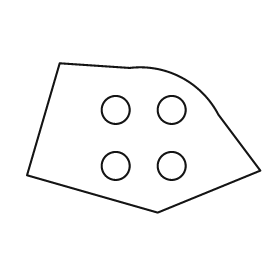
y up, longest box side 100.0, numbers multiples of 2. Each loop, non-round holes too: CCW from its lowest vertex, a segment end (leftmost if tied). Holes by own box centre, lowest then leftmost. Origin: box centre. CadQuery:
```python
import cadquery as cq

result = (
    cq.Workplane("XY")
    .moveTo(6.0, -32.0)
    .lineTo(50.0, -14.0)
    .lineTo(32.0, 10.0)
    .threePointArc((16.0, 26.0), (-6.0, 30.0))
    .lineTo(-36.0, 32.0)
    .lineTo(-50.0, -16.0)
    .close()
    .moveTo(-12.0, -12.0)
    .circle(6.0)
    .moveTo(12.0, -12.0)
    .circle(6.0)
    .moveTo(-12.0, 12.0)
    .circle(6.0)
    .moveTo(12.0, 12.0)
    .circle(6.0)
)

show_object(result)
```